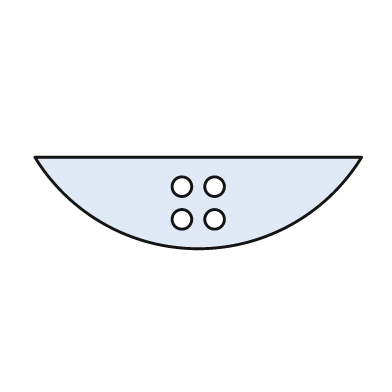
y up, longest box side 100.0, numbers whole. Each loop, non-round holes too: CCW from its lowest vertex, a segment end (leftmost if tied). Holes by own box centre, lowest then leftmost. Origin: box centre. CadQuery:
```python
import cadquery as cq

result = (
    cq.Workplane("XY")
    .moveTo(-50.0, 14.0)
    .threePointArc((0.0, -14.0), (50.0, 14.0))
    .close()
    .moveTo(-5.0, -5.0)
    .circle(3.0)
    .moveTo(5.0, -5.0)
    .circle(3.0)
    .moveTo(-5.0, 5.0)
    .circle(3.0)
    .moveTo(5.0, 5.0)
    .circle(3.0)
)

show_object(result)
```